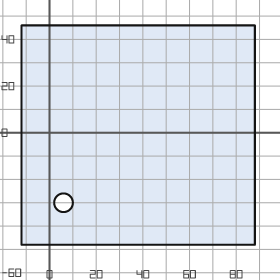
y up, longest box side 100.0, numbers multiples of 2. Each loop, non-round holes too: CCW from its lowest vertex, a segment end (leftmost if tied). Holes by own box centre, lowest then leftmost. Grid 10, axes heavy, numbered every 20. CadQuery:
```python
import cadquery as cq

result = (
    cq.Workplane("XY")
    .moveTo(-12.0, -48.0)
    .lineTo(88.0, -48.0)
    .lineTo(88.0, 46.0)
    .lineTo(-12.0, 46.0)
    .close()
    .moveTo(6.0, -30.0)
    .circle(4.0)
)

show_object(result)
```